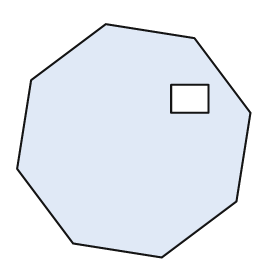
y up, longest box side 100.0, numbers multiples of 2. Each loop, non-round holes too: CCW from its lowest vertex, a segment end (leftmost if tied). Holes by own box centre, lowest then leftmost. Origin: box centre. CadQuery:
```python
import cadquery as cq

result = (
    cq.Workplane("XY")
    .moveTo(12.0, -50.0)
    .lineTo(44.0, -26.0)
    .lineTo(50.0, 12.0)
    .lineTo(26.0, 44.0)
    .lineTo(-12.0, 50.0)
    .lineTo(-44.0, 26.0)
    .lineTo(-50.0, -12.0)
    .lineTo(-26.0, -44.0)
    .close()
    .moveTo(16.0, 12.0)
    .lineTo(32.0, 12.0)
    .lineTo(32.0, 24.0)
    .lineTo(16.0, 24.0)
    .close()
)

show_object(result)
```